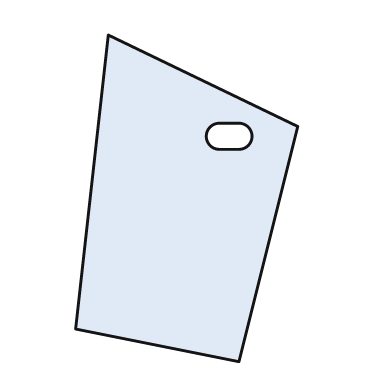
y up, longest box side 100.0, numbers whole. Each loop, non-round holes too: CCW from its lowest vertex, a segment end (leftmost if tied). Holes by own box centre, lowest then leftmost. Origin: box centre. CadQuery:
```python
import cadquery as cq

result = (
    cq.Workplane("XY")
    .moveTo(16.0, -50.0)
    .lineTo(34.0, 22.0)
    .lineTo(-24.0, 50.0)
    .lineTo(-34.0, -40.0)
    .close()
    .moveTo(10.0, 15.0)
    .lineTo(16.0, 15.0)
    .threePointArc((20.0, 19.0), (16.0, 23.0))
    .lineTo(10.0, 23.0)
    .threePointArc((6.0, 19.0), (10.0, 15.0))
    .close()
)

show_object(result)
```